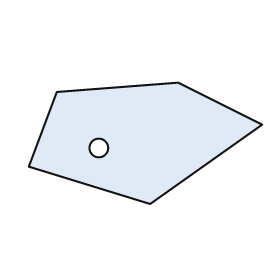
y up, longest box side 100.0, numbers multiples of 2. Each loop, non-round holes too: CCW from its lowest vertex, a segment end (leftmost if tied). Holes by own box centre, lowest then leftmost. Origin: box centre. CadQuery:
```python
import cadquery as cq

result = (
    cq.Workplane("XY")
    .moveTo(2.0, -26.0)
    .lineTo(50.0, 8.0)
    .lineTo(14.0, 26.0)
    .lineTo(-38.0, 22.0)
    .lineTo(-50.0, -10.0)
    .close()
    .moveTo(-20.0, -2.0)
    .circle(4.0)
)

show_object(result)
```